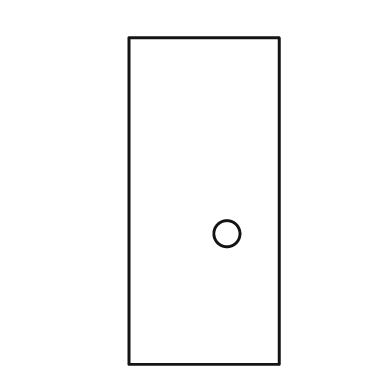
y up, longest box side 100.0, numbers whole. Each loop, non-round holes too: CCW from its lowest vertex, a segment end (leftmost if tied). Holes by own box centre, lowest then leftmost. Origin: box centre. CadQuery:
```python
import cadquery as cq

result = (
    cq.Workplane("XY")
    .moveTo(-23.0, -50.0)
    .lineTo(23.0, -50.0)
    .lineTo(23.0, 50.0)
    .lineTo(-23.0, 50.0)
    .close()
    .moveTo(7.0, -10.0)
    .circle(4.0)
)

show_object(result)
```